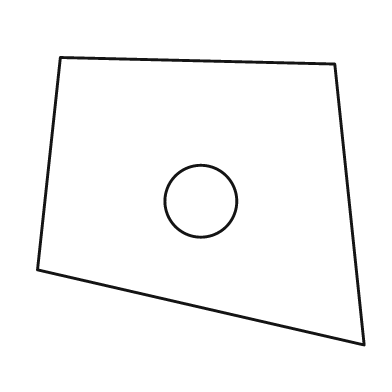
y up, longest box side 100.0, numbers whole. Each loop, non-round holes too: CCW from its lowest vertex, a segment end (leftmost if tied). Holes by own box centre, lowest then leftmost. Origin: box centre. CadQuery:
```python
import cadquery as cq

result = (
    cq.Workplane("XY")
    .moveTo(50.0, -44.0)
    .lineTo(41.0, 42.0)
    .lineTo(-43.0, 44.0)
    .lineTo(-50.0, -21.0)
    .close()
    .moveTo(0.0, 0.0)
    .circle(11.0)
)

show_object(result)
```